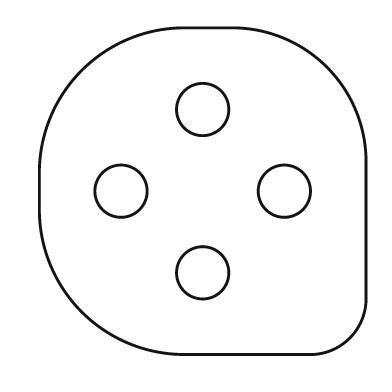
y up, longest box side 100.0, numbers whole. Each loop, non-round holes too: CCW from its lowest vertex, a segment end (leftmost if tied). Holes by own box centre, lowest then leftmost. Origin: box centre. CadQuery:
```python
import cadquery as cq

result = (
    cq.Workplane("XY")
    .moveTo(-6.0, -50.0)
    .lineTo(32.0, -50.0)
    .threePointArc((45.0, -45.0), (50.0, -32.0))
    .lineTo(50.0, 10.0)
    .threePointArc((38.0, 38.0), (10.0, 50.0))
    .lineTo(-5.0, 50.0)
    .threePointArc((-37.0, 37.0), (-50.0, 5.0))
    .lineTo(-50.0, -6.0)
    .threePointArc((-37.0, -37.0), (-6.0, -50.0))
    .close()
    .moveTo(0.0, -25.0)
    .circle(8.0)
    .moveTo(-25.0, 0.0)
    .circle(8.0)
    .moveTo(25.0, 0.0)
    .circle(8.0)
    .moveTo(0.0, 25.0)
    .circle(8.0)
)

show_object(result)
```